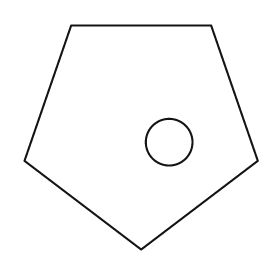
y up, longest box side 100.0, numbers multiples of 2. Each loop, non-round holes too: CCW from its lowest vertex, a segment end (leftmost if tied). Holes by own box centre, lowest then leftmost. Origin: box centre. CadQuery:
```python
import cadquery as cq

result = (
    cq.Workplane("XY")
    .moveTo(0.0, -48.0)
    .lineTo(50.0, -10.0)
    .lineTo(30.0, 48.0)
    .lineTo(-30.0, 48.0)
    .lineTo(-50.0, -10.0)
    .close()
    .moveTo(12.0, -2.0)
    .circle(10.0)
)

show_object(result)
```